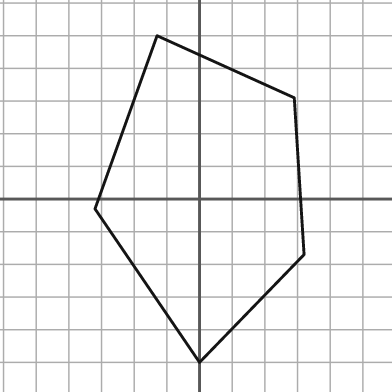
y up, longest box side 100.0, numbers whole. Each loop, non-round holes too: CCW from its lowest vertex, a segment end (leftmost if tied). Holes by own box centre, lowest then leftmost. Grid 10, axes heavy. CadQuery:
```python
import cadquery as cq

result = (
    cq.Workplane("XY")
    .moveTo(0.0, -50.0)
    .lineTo(32.0, -17.0)
    .lineTo(29.0, 31.0)
    .lineTo(-13.0, 50.0)
    .lineTo(-32.0, -3.0)
    .close()
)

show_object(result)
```